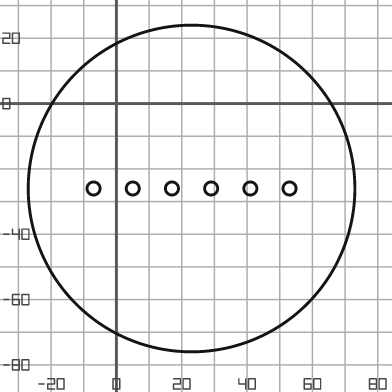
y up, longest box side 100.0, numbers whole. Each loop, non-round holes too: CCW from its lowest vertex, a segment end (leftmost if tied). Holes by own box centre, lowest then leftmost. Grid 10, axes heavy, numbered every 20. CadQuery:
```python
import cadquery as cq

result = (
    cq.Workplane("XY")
    .moveTo(23.0, -26.0)
    .circle(50.0)
    .moveTo(-7.0, -26.0)
    .circle(2.0)
    .moveTo(5.0, -26.0)
    .circle(2.0)
    .moveTo(17.0, -26.0)
    .circle(2.0)
    .moveTo(29.0, -26.0)
    .circle(2.0)
    .moveTo(41.0, -26.0)
    .circle(2.0)
    .moveTo(53.0, -26.0)
    .circle(2.0)
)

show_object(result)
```